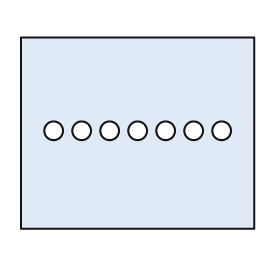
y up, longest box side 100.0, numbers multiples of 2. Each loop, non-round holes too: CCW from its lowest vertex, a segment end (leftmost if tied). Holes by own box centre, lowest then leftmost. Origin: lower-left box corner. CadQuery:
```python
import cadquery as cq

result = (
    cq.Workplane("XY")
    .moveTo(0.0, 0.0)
    .lineTo(100.0, 0.0)
    .lineTo(100.0, 82.0)
    .lineTo(0.0, 82.0)
    .close()
    .moveTo(14.0, 42.0)
    .circle(4.0)
    .moveTo(26.0, 42.0)
    .circle(4.0)
    .moveTo(38.0, 42.0)
    .circle(4.0)
    .moveTo(50.0, 42.0)
    .circle(4.0)
    .moveTo(62.0, 42.0)
    .circle(4.0)
    .moveTo(74.0, 42.0)
    .circle(4.0)
    .moveTo(86.0, 42.0)
    .circle(4.0)
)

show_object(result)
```